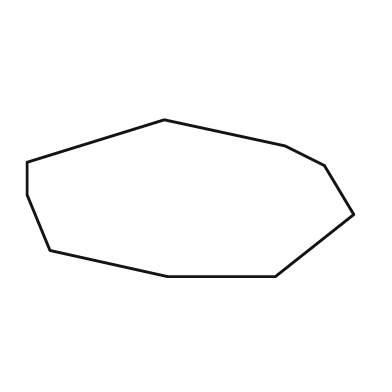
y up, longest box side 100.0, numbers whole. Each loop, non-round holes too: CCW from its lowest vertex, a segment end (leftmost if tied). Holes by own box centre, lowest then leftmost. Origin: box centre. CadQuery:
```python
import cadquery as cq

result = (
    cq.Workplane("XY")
    .moveTo(-7.0, -24.0)
    .lineTo(26.0, -24.0)
    .lineTo(50.0, -5.0)
    .lineTo(41.0, 10.0)
    .lineTo(29.0, 16.0)
    .lineTo(-8.0, 24.0)
    .lineTo(-50.0, 11.0)
    .lineTo(-50.0, 1.0)
    .lineTo(-43.0, -16.0)
    .close()
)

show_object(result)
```